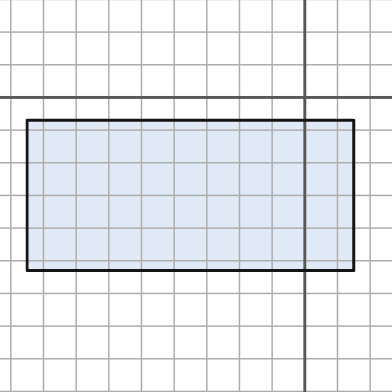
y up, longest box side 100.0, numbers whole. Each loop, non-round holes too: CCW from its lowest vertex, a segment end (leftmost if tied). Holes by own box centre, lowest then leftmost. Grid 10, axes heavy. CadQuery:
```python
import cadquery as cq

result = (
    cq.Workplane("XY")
    .moveTo(-85.0, -53.0)
    .lineTo(15.0, -53.0)
    .lineTo(15.0, -7.0)
    .lineTo(-85.0, -7.0)
    .close()
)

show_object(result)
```